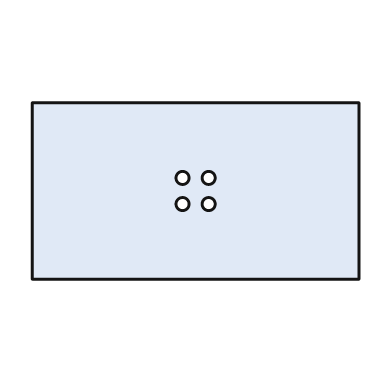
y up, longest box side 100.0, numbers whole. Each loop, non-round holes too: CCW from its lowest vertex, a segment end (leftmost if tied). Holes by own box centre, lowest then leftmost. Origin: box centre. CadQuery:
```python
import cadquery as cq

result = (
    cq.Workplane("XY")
    .moveTo(-50.0, -27.0)
    .lineTo(50.0, -27.0)
    .lineTo(50.0, 27.0)
    .lineTo(-50.0, 27.0)
    .close()
    .moveTo(-4.0, -4.0)
    .circle(2.0)
    .moveTo(4.0, -4.0)
    .circle(2.0)
    .moveTo(-4.0, 4.0)
    .circle(2.0)
    .moveTo(4.0, 4.0)
    .circle(2.0)
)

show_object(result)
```